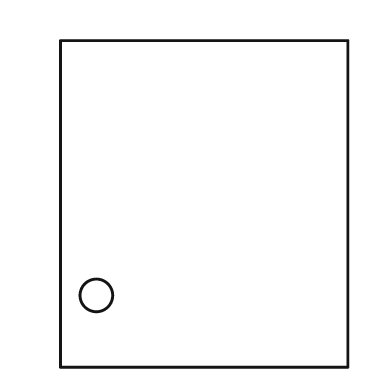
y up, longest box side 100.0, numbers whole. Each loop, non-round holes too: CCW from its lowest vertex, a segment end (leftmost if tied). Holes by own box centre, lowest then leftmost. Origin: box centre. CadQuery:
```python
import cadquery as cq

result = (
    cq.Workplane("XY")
    .moveTo(-44.0, -50.0)
    .lineTo(44.0, -50.0)
    .lineTo(44.0, 50.0)
    .lineTo(-44.0, 50.0)
    .close()
    .moveTo(-33.0, -28.0)
    .circle(5.0)
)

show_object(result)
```